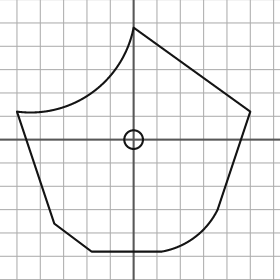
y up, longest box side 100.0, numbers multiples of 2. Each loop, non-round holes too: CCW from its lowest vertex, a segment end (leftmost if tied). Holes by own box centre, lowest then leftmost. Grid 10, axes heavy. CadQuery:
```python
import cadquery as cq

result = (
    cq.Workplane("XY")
    .moveTo(-18.0, -48.0)
    .lineTo(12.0, -48.0)
    .threePointArc((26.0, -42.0), (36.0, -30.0))
    .lineTo(50.0, 12.0)
    .lineTo(0.0, 48.0)
    .threePointArc((-18.0, 20.0), (-50.0, 12.0))
    .lineTo(-34.0, -36.0)
    .close()
    .moveTo(0.0, 0.0)
    .circle(4.0)
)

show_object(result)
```